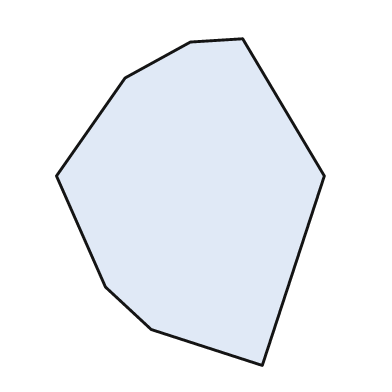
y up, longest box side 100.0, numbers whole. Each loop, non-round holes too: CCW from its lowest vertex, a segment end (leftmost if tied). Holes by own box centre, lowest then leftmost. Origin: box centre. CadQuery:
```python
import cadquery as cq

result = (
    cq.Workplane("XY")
    .moveTo(22.0, -50.0)
    .lineTo(41.0, 8.0)
    .lineTo(16.0, 50.0)
    .lineTo(0.0, 49.0)
    .lineTo(-20.0, 38.0)
    .lineTo(-41.0, 8.0)
    .lineTo(-26.0, -26.0)
    .lineTo(-12.0, -39.0)
    .close()
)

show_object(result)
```